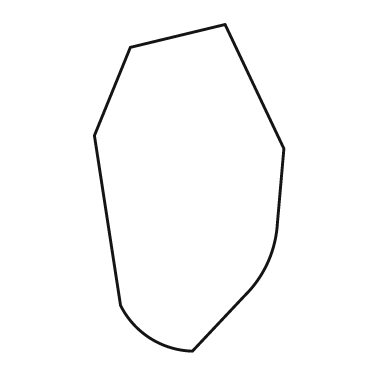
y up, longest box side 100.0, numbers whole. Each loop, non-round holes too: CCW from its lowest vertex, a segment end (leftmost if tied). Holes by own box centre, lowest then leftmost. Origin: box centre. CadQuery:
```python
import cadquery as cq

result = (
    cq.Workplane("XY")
    .moveTo(1.0, -50.0)
    .lineTo(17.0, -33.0)
    .threePointArc((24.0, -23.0), (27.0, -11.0))
    .lineTo(29.0, 12.0)
    .lineTo(11.0, 50.0)
    .lineTo(-18.0, 43.0)
    .lineTo(-29.0, 16.0)
    .lineTo(-21.0, -36.0)
    .threePointArc((-12.0, -46.0), (1.0, -50.0))
    .close()
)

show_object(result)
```